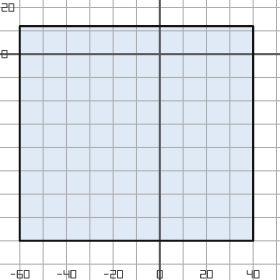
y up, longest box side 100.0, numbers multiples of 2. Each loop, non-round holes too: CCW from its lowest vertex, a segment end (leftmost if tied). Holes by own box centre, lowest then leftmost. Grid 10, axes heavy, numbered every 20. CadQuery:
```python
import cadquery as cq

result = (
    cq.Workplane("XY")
    .moveTo(-60.0, -80.0)
    .lineTo(40.0, -80.0)
    .lineTo(40.0, 12.0)
    .lineTo(-60.0, 12.0)
    .close()
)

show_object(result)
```